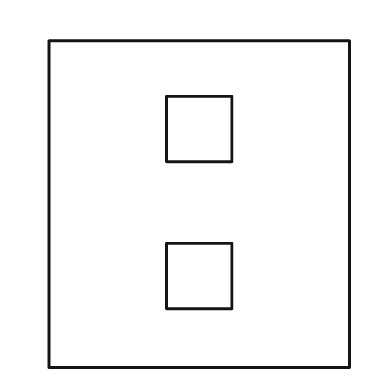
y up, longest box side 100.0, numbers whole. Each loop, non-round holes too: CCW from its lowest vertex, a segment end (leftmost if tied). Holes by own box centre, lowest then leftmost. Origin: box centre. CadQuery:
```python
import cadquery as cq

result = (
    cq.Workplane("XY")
    .moveTo(-46.0, -50.0)
    .lineTo(46.0, -50.0)
    .lineTo(46.0, 50.0)
    .lineTo(-46.0, 50.0)
    .close()
    .moveTo(-10.0, -32.0)
    .lineTo(10.0, -32.0)
    .lineTo(10.0, -12.0)
    .lineTo(-10.0, -12.0)
    .close()
    .moveTo(-10.0, 13.0)
    .lineTo(10.0, 13.0)
    .lineTo(10.0, 33.0)
    .lineTo(-10.0, 33.0)
    .close()
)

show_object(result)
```